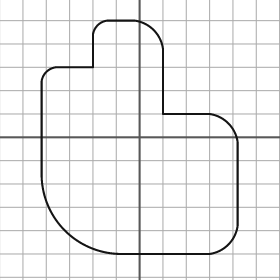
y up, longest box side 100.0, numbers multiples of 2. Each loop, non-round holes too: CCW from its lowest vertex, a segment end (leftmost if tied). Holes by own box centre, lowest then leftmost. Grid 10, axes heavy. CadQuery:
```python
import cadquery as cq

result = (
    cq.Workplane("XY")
    .moveTo(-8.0, -50.0)
    .lineTo(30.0, -50.0)
    .threePointArc((38.0, -46.0), (42.0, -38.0))
    .lineTo(42.0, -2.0)
    .threePointArc((38.0, 6.0), (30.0, 10.0))
    .lineTo(10.0, 10.0)
    .lineTo(10.0, 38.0)
    .threePointArc((6.0, 46.0), (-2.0, 50.0))
    .lineTo(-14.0, 50.0)
    .threePointArc((-18.0, 48.0), (-20.0, 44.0))
    .lineTo(-20.0, 30.0)
    .lineTo(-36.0, 30.0)
    .threePointArc((-40.0, 28.0), (-42.0, 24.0))
    .lineTo(-42.0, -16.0)
    .threePointArc((-32.0, -40.0), (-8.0, -50.0))
    .close()
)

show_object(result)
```